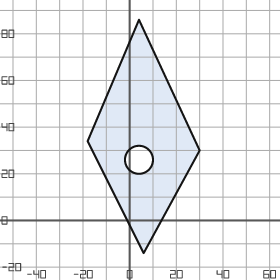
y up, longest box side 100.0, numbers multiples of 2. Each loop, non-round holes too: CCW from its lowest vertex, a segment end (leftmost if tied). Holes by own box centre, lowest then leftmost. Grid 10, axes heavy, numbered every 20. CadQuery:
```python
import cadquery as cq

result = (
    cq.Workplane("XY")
    .moveTo(6.0, -14.0)
    .lineTo(30.0, 30.0)
    .lineTo(4.0, 86.0)
    .lineTo(-18.0, 34.0)
    .close()
    .moveTo(4.0, 26.0)
    .circle(6.0)
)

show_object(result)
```